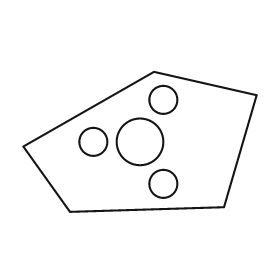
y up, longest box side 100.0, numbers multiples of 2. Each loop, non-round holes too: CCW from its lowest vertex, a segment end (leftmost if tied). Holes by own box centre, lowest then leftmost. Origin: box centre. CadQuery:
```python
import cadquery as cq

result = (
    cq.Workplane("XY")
    .moveTo(-30.0, -30.0)
    .lineTo(36.0, -28.0)
    .lineTo(50.0, 20.0)
    .lineTo(6.0, 30.0)
    .lineTo(-50.0, -2.0)
    .close()
    .moveTo(10.0, -18.0)
    .circle(6.0)
    .moveTo(-20.0, 0.0)
    .circle(6.0)
    .moveTo(0.0, 0.0)
    .circle(10.0)
    .moveTo(10.0, 18.0)
    .circle(6.0)
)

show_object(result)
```